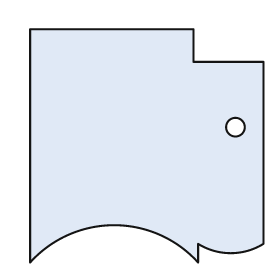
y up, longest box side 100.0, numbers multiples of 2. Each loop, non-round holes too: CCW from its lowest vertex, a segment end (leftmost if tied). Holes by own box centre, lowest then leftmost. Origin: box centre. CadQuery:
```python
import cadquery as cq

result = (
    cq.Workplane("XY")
    .moveTo(-50.0, -50.0)
    .threePointArc((-14.0, -34.0), (22.0, -50.0))
    .lineTo(22.0, -42.0)
    .threePointArc((36.0, -46.0), (50.0, -42.0))
    .lineTo(50.0, 36.0)
    .lineTo(20.0, 36.0)
    .lineTo(20.0, 50.0)
    .lineTo(-50.0, 50.0)
    .close()
    .moveTo(38.0, 8.0)
    .circle(4.0)
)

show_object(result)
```